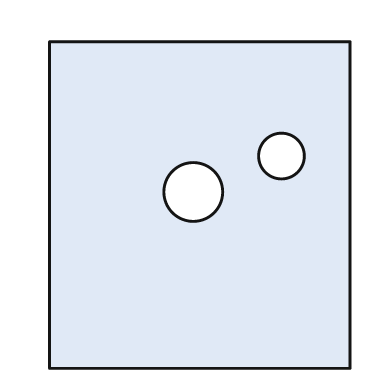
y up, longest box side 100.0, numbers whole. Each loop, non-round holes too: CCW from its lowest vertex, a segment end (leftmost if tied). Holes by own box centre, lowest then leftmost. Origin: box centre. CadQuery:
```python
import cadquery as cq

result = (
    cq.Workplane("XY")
    .moveTo(-46.0, -50.0)
    .lineTo(46.0, -50.0)
    .lineTo(46.0, 50.0)
    .lineTo(-46.0, 50.0)
    .close()
    .moveTo(-2.0, 4.0)
    .circle(9.0)
    .moveTo(25.0, 15.0)
    .circle(7.0)
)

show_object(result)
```